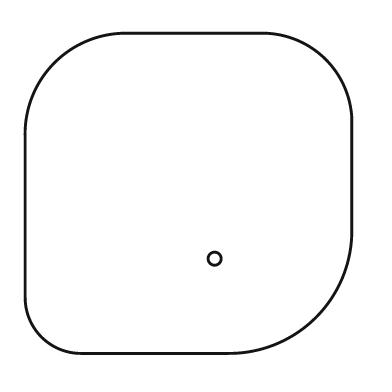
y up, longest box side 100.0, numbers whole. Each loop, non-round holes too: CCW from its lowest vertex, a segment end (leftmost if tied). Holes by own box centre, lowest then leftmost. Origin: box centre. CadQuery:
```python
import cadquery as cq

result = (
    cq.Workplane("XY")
    .moveTo(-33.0, -49.0)
    .lineTo(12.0, -49.0)
    .threePointArc((39.0, -38.0), (50.0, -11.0))
    .lineTo(50.0, 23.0)
    .threePointArc((42.0, 41.0), (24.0, 49.0))
    .lineTo(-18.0, 49.0)
    .threePointArc((-41.0, 40.0), (-50.0, 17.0))
    .lineTo(-50.0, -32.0)
    .threePointArc((-45.0, -44.0), (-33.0, -49.0))
    .close()
    .moveTo(8.0, -20.0)
    .circle(2.0)
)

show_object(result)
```